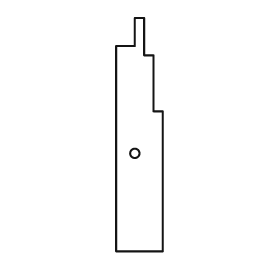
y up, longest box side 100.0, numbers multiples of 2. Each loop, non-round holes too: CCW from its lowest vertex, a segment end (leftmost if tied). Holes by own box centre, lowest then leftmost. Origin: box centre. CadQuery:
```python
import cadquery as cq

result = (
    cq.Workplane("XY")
    .moveTo(-10.0, -50.0)
    .lineTo(10.0, -50.0)
    .lineTo(10.0, 10.0)
    .lineTo(6.0, 10.0)
    .lineTo(6.0, 34.0)
    .lineTo(2.0, 34.0)
    .lineTo(2.0, 50.0)
    .lineTo(-2.0, 50.0)
    .lineTo(-2.0, 38.0)
    .lineTo(-10.0, 38.0)
    .close()
    .moveTo(-2.0, -8.0)
    .circle(2.0)
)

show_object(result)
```